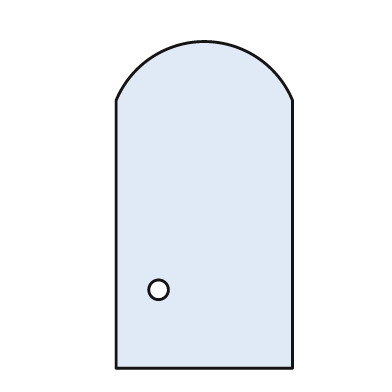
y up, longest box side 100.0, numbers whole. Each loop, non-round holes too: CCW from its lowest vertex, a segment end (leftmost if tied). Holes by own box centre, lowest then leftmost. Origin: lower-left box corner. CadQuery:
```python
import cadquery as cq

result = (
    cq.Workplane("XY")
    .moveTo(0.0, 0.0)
    .lineTo(54.0, 0.0)
    .lineTo(54.0, 82.0)
    .threePointArc((27.0, 100.0), (0.0, 82.0))
    .close()
    .moveTo(13.0, 24.0)
    .circle(3.0)
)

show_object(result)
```